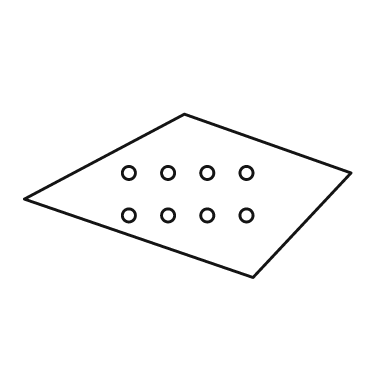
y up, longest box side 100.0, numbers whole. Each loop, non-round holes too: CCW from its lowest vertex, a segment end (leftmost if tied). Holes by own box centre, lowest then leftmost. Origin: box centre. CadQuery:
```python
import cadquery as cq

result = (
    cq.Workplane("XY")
    .moveTo(20.0, -25.0)
    .lineTo(50.0, 7.0)
    .lineTo(-1.0, 25.0)
    .lineTo(-50.0, -1.0)
    .close()
    .moveTo(-18.0, -6.0)
    .circle(2.0)
    .moveTo(-6.0, -6.0)
    .circle(2.0)
    .moveTo(6.0, -6.0)
    .circle(2.0)
    .moveTo(18.0, -6.0)
    .circle(2.0)
    .moveTo(-18.0, 7.0)
    .circle(2.0)
    .moveTo(-6.0, 7.0)
    .circle(2.0)
    .moveTo(6.0, 7.0)
    .circle(2.0)
    .moveTo(18.0, 7.0)
    .circle(2.0)
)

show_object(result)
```